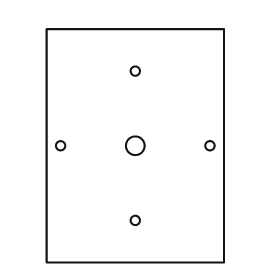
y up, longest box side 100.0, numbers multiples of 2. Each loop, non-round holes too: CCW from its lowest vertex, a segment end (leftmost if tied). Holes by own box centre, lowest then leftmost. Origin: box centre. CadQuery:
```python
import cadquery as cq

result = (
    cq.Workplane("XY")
    .moveTo(-38.0, -50.0)
    .lineTo(38.0, -50.0)
    .lineTo(38.0, 50.0)
    .lineTo(-38.0, 50.0)
    .close()
    .moveTo(0.0, -32.0)
    .circle(2.0)
    .moveTo(-32.0, 0.0)
    .circle(2.0)
    .moveTo(0.0, 0.0)
    .circle(4.0)
    .moveTo(32.0, 0.0)
    .circle(2.0)
    .moveTo(0.0, 32.0)
    .circle(2.0)
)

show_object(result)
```